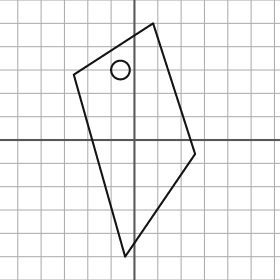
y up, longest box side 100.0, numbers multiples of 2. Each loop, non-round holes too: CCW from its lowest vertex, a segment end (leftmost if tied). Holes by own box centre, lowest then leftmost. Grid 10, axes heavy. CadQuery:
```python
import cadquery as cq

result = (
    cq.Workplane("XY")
    .moveTo(-4.0, -50.0)
    .lineTo(26.0, -6.0)
    .lineTo(8.0, 50.0)
    .lineTo(-26.0, 28.0)
    .close()
    .moveTo(-6.0, 30.0)
    .circle(4.0)
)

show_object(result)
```